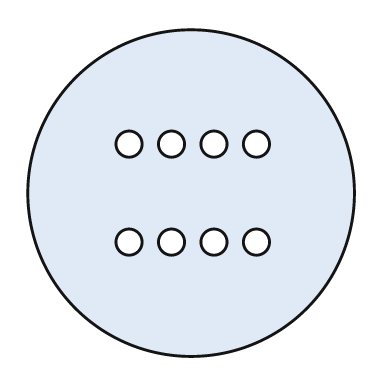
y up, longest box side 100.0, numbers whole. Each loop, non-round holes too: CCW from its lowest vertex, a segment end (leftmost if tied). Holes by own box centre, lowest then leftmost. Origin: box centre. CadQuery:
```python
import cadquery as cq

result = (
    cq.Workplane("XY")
    .moveTo(0.0, 0.0)
    .circle(50.0)
    .moveTo(-19.0, -15.0)
    .circle(4.0)
    .moveTo(-6.0, -15.0)
    .circle(4.0)
    .moveTo(7.0, -15.0)
    .circle(4.0)
    .moveTo(20.0, -15.0)
    .circle(4.0)
    .moveTo(-19.0, 15.0)
    .circle(4.0)
    .moveTo(-6.0, 15.0)
    .circle(4.0)
    .moveTo(7.0, 15.0)
    .circle(4.0)
    .moveTo(20.0, 15.0)
    .circle(4.0)
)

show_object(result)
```